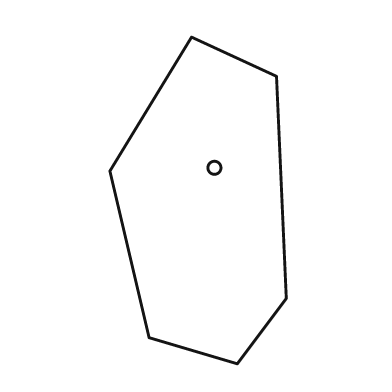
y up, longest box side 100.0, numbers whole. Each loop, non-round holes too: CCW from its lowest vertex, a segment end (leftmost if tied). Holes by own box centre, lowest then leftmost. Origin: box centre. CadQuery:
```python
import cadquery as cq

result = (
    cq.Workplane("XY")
    .moveTo(12.0, -50.0)
    .lineTo(27.0, -30.0)
    .lineTo(24.0, 38.0)
    .lineTo(-2.0, 50.0)
    .lineTo(-27.0, 9.0)
    .lineTo(-15.0, -42.0)
    .close()
    .moveTo(5.0, 10.0)
    .circle(2.0)
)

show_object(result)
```